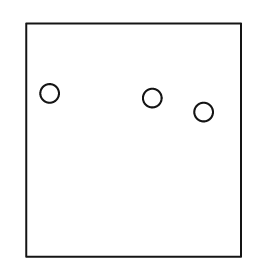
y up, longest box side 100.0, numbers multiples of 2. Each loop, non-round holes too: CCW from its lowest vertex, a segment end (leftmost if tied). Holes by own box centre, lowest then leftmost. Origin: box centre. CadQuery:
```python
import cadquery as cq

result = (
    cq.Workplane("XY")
    .moveTo(-46.0, -50.0)
    .lineTo(46.0, -50.0)
    .lineTo(46.0, 50.0)
    .lineTo(-46.0, 50.0)
    .close()
    .moveTo(30.0, 12.0)
    .circle(4.0)
    .moveTo(8.0, 18.0)
    .circle(4.0)
    .moveTo(-36.0, 20.0)
    .circle(4.0)
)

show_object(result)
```